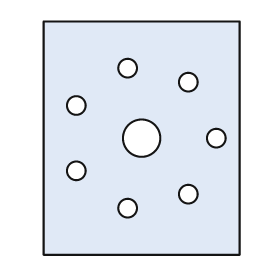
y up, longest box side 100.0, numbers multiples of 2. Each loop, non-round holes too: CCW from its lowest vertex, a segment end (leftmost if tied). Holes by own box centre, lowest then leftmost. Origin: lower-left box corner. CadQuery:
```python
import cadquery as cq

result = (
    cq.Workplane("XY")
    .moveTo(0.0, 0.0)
    .lineTo(84.0, 0.0)
    .lineTo(84.0, 100.0)
    .lineTo(0.0, 100.0)
    .close()
    .moveTo(36.0, 20.0)
    .circle(4.0)
    .moveTo(62.0, 26.0)
    .circle(4.0)
    .moveTo(14.0, 36.0)
    .circle(4.0)
    .moveTo(42.0, 50.0)
    .circle(8.0)
    .moveTo(74.0, 50.0)
    .circle(4.0)
    .moveTo(14.0, 64.0)
    .circle(4.0)
    .moveTo(62.0, 74.0)
    .circle(4.0)
    .moveTo(36.0, 80.0)
    .circle(4.0)
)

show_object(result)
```